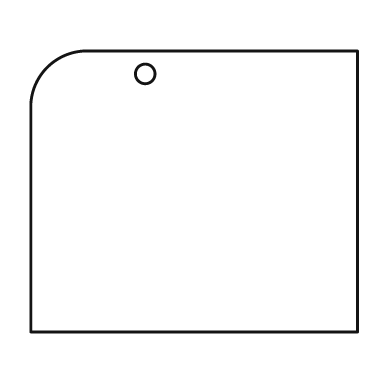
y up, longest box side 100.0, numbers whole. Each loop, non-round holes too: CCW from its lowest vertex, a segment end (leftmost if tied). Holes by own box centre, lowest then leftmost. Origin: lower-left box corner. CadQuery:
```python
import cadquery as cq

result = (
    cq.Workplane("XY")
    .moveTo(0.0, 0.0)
    .lineTo(100.0, 0.0)
    .lineTo(100.0, 86.0)
    .lineTo(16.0, 86.0)
    .threePointArc((5.0, 81.0), (0.0, 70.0))
    .close()
    .moveTo(35.0, 79.0)
    .circle(3.0)
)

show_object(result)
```